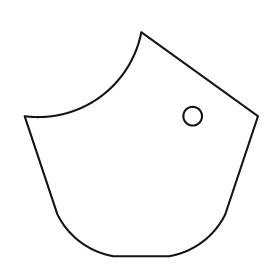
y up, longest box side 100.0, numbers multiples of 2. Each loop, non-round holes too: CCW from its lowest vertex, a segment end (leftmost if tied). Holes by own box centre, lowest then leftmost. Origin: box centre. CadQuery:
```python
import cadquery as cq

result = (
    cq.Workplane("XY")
    .moveTo(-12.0, -48.0)
    .lineTo(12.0, -48.0)
    .threePointArc((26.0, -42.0), (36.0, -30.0))
    .lineTo(50.0, 12.0)
    .lineTo(0.0, 48.0)
    .threePointArc((-18.0, 20.0), (-50.0, 12.0))
    .lineTo(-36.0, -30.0)
    .threePointArc((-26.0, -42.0), (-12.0, -48.0))
    .close()
    .moveTo(22.0, 12.0)
    .circle(4.0)
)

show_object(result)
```